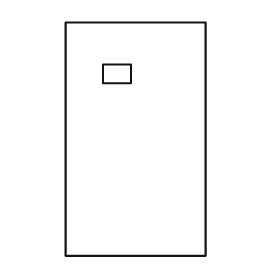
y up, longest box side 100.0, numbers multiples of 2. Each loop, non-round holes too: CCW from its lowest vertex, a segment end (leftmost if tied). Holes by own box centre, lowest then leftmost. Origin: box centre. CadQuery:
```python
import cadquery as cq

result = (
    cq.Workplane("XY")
    .moveTo(-30.0, -50.0)
    .lineTo(30.0, -50.0)
    .lineTo(30.0, 50.0)
    .lineTo(-30.0, 50.0)
    .close()
    .moveTo(-14.0, 24.0)
    .lineTo(-2.0, 24.0)
    .lineTo(-2.0, 32.0)
    .lineTo(-14.0, 32.0)
    .close()
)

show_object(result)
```